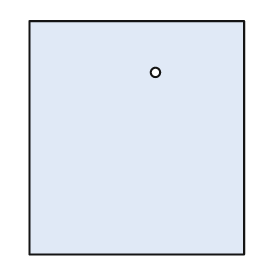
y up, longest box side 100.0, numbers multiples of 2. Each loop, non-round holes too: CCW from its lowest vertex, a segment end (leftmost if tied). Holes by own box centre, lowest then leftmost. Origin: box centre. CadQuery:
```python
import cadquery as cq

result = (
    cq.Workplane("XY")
    .moveTo(-46.0, -50.0)
    .lineTo(46.0, -50.0)
    .lineTo(46.0, 50.0)
    .lineTo(-46.0, 50.0)
    .close()
    .moveTo(8.0, 28.0)
    .circle(2.0)
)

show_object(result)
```